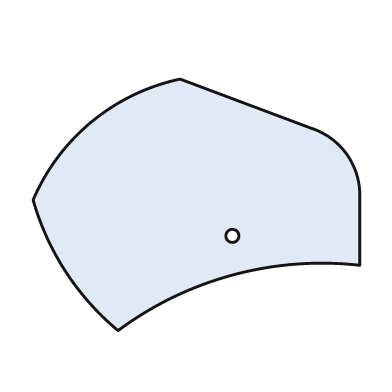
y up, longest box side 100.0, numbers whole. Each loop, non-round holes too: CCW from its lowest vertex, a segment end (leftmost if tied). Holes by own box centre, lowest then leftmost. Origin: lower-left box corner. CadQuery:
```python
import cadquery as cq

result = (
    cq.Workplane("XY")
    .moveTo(26.0, 0.0)
    .threePointArc((61.0, 17.0), (100.0, 20.0))
    .lineTo(100.0, 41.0)
    .threePointArc((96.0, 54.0), (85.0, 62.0))
    .lineTo(45.0, 77.0)
    .threePointArc((18.0, 64.0), (0.0, 40.0))
    .threePointArc((10.0, 18.0), (26.0, 0.0))
    .close()
    .moveTo(61.0, 29.0)
    .circle(2.0)
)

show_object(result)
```